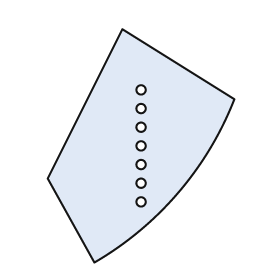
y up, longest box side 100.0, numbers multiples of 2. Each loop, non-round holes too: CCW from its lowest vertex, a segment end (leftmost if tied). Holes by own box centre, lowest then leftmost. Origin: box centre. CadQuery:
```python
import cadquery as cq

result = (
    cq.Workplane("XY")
    .moveTo(-20.0, -50.0)
    .threePointArc((16.0, -20.0), (40.0, 20.0))
    .lineTo(-8.0, 50.0)
    .lineTo(-40.0, -14.0)
    .close()
    .moveTo(0.0, -24.0)
    .circle(2.0)
    .moveTo(0.0, -16.0)
    .circle(2.0)
    .moveTo(0.0, -8.0)
    .circle(2.0)
    .moveTo(0.0, 0.0)
    .circle(2.0)
    .moveTo(0.0, 8.0)
    .circle(2.0)
    .moveTo(0.0, 16.0)
    .circle(2.0)
    .moveTo(0.0, 24.0)
    .circle(2.0)
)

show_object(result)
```